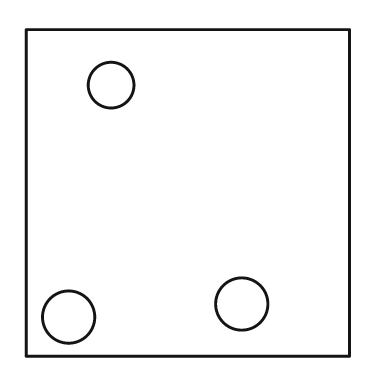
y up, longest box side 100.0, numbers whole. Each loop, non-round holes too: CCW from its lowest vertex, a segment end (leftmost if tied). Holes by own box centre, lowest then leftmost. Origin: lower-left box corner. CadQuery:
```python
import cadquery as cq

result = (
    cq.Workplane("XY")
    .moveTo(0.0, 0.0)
    .lineTo(99.0, 0.0)
    .lineTo(99.0, 100.0)
    .lineTo(0.0, 100.0)
    .close()
    .moveTo(13.0, 12.0)
    .circle(8.0)
    .moveTo(66.0, 16.0)
    .circle(8.0)
    .moveTo(26.0, 83.0)
    .circle(7.0)
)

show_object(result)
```